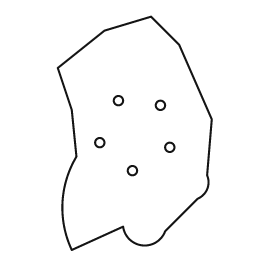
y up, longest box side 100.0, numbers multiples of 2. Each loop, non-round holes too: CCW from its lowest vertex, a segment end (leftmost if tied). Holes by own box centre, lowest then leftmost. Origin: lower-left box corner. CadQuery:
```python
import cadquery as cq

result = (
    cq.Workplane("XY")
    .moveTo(6.0, 0.0)
    .lineTo(28.0, 10.0)
    .threePointArc((36.0, 2.0), (46.0, 8.0))
    .lineTo(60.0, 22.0)
    .threePointArc((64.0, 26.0), (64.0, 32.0))
    .lineTo(66.0, 56.0)
    .lineTo(52.0, 88.0)
    .lineTo(40.0, 100.0)
    .lineTo(20.0, 94.0)
    .lineTo(0.0, 78.0)
    .lineTo(6.0, 60.0)
    .lineTo(8.0, 40.0)
    .threePointArc((2.0, 20.0), (6.0, 0.0))
    .close()
    .moveTo(32.0, 34.0)
    .circle(2.0)
    .moveTo(48.0, 44.0)
    .circle(2.0)
    .moveTo(18.0, 46.0)
    .circle(2.0)
    .moveTo(44.0, 62.0)
    .circle(2.0)
    .moveTo(26.0, 64.0)
    .circle(2.0)
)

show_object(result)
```